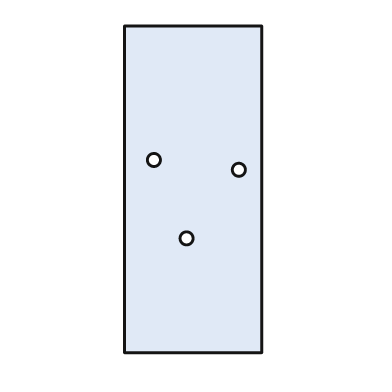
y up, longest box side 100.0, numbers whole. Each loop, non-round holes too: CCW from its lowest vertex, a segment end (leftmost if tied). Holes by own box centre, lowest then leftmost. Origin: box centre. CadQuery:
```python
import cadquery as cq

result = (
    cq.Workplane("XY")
    .moveTo(-21.0, -50.0)
    .lineTo(21.0, -50.0)
    .lineTo(21.0, 50.0)
    .lineTo(-21.0, 50.0)
    .close()
    .moveTo(-2.0, -15.0)
    .circle(2.0)
    .moveTo(14.0, 6.0)
    .circle(2.0)
    .moveTo(-12.0, 9.0)
    .circle(2.0)
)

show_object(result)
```